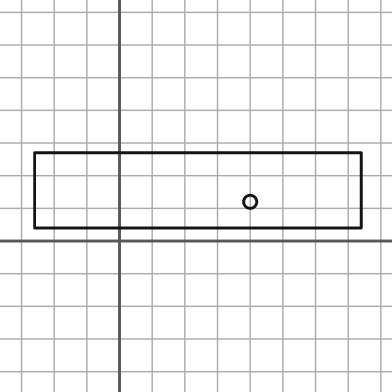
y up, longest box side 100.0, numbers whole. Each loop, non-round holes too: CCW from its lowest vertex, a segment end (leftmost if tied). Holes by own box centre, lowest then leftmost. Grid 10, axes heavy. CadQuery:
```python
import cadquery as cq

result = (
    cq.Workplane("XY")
    .moveTo(-26.0, 4.0)
    .lineTo(74.0, 4.0)
    .lineTo(74.0, 27.0)
    .lineTo(-26.0, 27.0)
    .close()
    .moveTo(40.0, 12.0)
    .circle(2.0)
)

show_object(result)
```